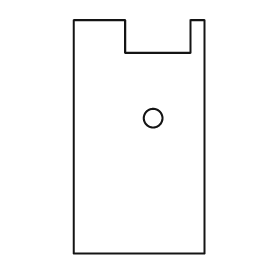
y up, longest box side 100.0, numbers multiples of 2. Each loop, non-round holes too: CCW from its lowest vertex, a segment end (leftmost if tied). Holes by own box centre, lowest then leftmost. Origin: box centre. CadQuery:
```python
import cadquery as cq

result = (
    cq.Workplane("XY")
    .moveTo(-28.0, -50.0)
    .lineTo(28.0, -50.0)
    .lineTo(28.0, 50.0)
    .lineTo(22.0, 50.0)
    .lineTo(22.0, 36.0)
    .lineTo(-6.0, 36.0)
    .lineTo(-6.0, 50.0)
    .lineTo(-28.0, 50.0)
    .close()
    .moveTo(6.0, 8.0)
    .circle(4.0)
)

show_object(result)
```